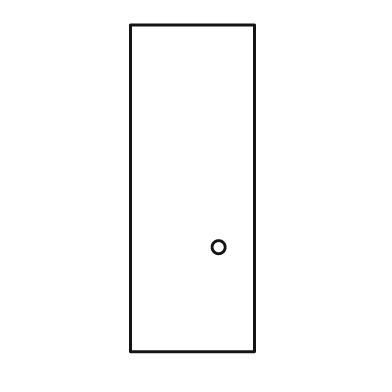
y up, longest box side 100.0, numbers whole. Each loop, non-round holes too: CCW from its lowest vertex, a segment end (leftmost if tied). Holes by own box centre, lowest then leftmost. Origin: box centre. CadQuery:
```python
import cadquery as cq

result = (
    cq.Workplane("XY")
    .moveTo(-19.0, -50.0)
    .lineTo(19.0, -50.0)
    .lineTo(19.0, 50.0)
    .lineTo(-19.0, 50.0)
    .close()
    .moveTo(8.0, -18.0)
    .circle(2.0)
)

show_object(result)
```